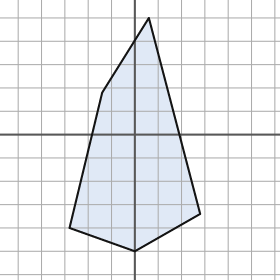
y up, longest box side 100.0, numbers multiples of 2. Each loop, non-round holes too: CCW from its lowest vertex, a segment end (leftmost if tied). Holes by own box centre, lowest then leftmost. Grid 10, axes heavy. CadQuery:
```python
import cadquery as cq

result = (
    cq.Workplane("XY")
    .moveTo(0.0, -50.0)
    .lineTo(28.0, -34.0)
    .lineTo(6.0, 50.0)
    .lineTo(-14.0, 18.0)
    .lineTo(-28.0, -40.0)
    .close()
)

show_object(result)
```